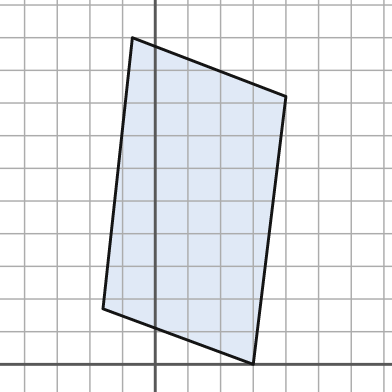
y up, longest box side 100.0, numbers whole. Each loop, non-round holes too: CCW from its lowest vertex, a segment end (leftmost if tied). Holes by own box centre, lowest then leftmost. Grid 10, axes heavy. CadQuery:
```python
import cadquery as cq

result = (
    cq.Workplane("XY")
    .moveTo(30.0, 0.0)
    .lineTo(40.0, 82.0)
    .lineTo(-7.0, 100.0)
    .lineTo(-16.0, 17.0)
    .close()
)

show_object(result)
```